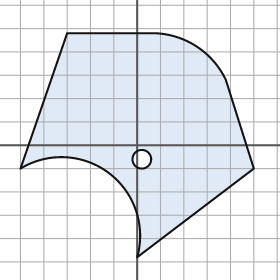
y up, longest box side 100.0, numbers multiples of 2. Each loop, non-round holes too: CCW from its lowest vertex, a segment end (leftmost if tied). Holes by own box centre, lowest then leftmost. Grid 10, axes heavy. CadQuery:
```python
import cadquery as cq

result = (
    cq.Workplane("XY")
    .moveTo(0.0, -48.0)
    .lineTo(50.0, -10.0)
    .lineTo(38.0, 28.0)
    .threePointArc((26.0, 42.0), (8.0, 48.0))
    .lineTo(-30.0, 48.0)
    .lineTo(-50.0, -10.0)
    .threePointArc((-12.0, -12.0), (0.0, -48.0))
    .close()
    .moveTo(2.0, -6.0)
    .circle(4.0)
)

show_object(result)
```